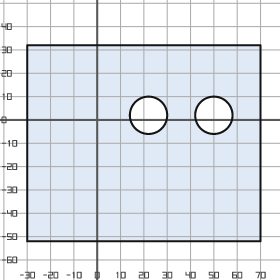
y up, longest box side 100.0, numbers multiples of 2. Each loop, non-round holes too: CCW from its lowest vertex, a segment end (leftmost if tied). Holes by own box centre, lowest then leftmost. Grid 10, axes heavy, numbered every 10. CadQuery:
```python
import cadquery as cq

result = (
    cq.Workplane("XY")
    .moveTo(-30.0, -52.0)
    .lineTo(70.0, -52.0)
    .lineTo(70.0, 32.0)
    .lineTo(-30.0, 32.0)
    .close()
    .moveTo(22.0, 2.0)
    .circle(8.0)
    .moveTo(50.0, 2.0)
    .circle(8.0)
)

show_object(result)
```